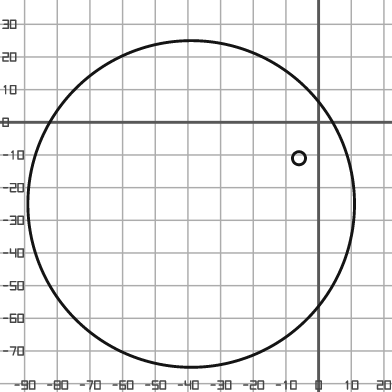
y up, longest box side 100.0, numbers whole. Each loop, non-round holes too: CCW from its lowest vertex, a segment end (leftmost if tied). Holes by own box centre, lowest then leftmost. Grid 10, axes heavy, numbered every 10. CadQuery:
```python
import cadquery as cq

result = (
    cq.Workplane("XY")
    .moveTo(-39.0, -25.0)
    .circle(50.0)
    .moveTo(-6.0, -11.0)
    .circle(2.0)
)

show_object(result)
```